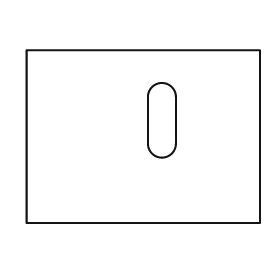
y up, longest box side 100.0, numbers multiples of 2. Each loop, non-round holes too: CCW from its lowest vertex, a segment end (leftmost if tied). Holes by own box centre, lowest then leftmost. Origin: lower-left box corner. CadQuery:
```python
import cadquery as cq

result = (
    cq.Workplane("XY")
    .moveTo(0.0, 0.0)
    .lineTo(100.0, 0.0)
    .lineTo(100.0, 74.0)
    .lineTo(0.0, 74.0)
    .close()
    .moveTo(52.0, 34.0)
    .threePointArc((58.0, 28.0), (64.0, 34.0))
    .lineTo(64.0, 54.0)
    .threePointArc((58.0, 60.0), (52.0, 54.0))
    .close()
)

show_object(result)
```